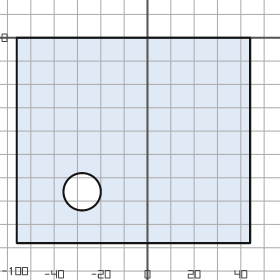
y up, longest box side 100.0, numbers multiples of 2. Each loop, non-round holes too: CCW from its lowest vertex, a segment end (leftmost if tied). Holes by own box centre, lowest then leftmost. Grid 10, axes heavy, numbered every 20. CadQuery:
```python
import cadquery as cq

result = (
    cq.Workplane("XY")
    .moveTo(-56.0, -88.0)
    .lineTo(44.0, -88.0)
    .lineTo(44.0, 0.0)
    .lineTo(-56.0, 0.0)
    .close()
    .moveTo(-28.0, -66.0)
    .circle(8.0)
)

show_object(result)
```